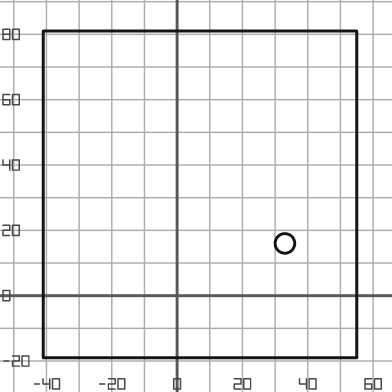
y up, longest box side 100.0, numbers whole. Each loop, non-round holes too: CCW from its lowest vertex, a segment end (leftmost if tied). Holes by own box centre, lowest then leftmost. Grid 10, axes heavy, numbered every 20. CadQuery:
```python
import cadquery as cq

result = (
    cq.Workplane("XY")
    .moveTo(-41.0, -19.0)
    .lineTo(55.0, -19.0)
    .lineTo(55.0, 81.0)
    .lineTo(-41.0, 81.0)
    .close()
    .moveTo(33.0, 16.0)
    .circle(3.0)
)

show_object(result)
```